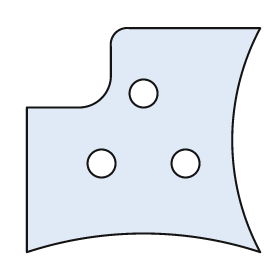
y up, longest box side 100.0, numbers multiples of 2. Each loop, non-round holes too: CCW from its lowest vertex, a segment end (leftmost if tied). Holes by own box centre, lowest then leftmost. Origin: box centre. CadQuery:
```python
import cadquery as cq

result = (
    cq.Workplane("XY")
    .moveTo(-50.0, -48.0)
    .threePointArc((0.0, -40.0), (50.0, -48.0))
    .threePointArc((38.0, 0.0), (50.0, 48.0))
    .lineTo(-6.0, 48.0)
    .threePointArc((-12.0, 46.0), (-14.0, 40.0))
    .lineTo(-14.0, 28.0)
    .threePointArc((-18.0, 18.0), (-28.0, 14.0))
    .lineTo(-50.0, 14.0)
    .close()
    .moveTo(-18.0, -10.0)
    .circle(6.0)
    .moveTo(18.0, -10.0)
    .circle(6.0)
    .moveTo(0.0, 20.0)
    .circle(6.0)
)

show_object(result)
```